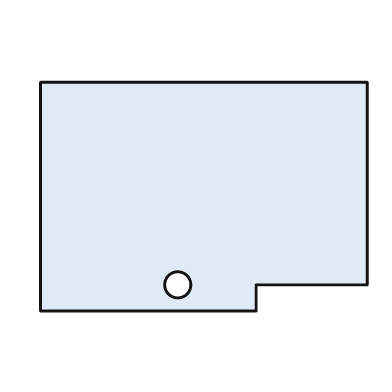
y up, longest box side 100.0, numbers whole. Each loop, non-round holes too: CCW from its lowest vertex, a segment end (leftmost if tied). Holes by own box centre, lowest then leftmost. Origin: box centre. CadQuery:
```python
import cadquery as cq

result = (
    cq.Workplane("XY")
    .moveTo(-50.0, -35.0)
    .lineTo(16.0, -35.0)
    .lineTo(16.0, -27.0)
    .lineTo(50.0, -27.0)
    .lineTo(50.0, 35.0)
    .lineTo(-50.0, 35.0)
    .close()
    .moveTo(-8.0, -27.0)
    .circle(4.0)
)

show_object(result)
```